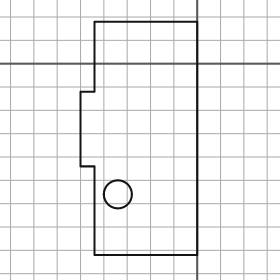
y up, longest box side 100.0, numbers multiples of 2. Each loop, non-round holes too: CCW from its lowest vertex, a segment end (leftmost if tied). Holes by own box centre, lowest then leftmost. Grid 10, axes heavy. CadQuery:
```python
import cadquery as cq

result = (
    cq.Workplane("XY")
    .moveTo(-44.0, -82.0)
    .lineTo(0.0, -82.0)
    .lineTo(0.0, 18.0)
    .lineTo(-44.0, 18.0)
    .lineTo(-44.0, -12.0)
    .lineTo(-50.0, -12.0)
    .lineTo(-50.0, -44.0)
    .lineTo(-44.0, -44.0)
    .close()
    .moveTo(-34.0, -56.0)
    .circle(6.0)
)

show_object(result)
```